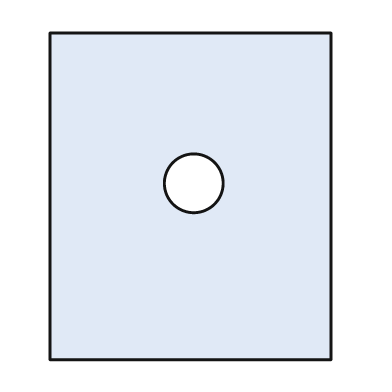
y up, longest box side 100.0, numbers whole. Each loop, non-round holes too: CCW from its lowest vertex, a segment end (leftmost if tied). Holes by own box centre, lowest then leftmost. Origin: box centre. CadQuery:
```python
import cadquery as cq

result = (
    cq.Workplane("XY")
    .moveTo(-43.0, -50.0)
    .lineTo(43.0, -50.0)
    .lineTo(43.0, 50.0)
    .lineTo(-43.0, 50.0)
    .close()
    .moveTo(1.0, 4.0)
    .circle(9.0)
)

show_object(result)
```